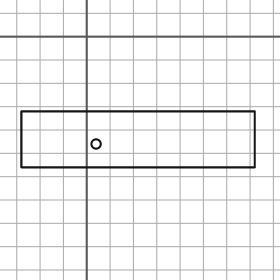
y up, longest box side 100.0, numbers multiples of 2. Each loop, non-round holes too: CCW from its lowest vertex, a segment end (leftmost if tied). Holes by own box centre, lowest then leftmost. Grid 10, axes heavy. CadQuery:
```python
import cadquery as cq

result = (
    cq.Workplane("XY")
    .moveTo(-28.0, -56.0)
    .lineTo(72.0, -56.0)
    .lineTo(72.0, -32.0)
    .lineTo(-28.0, -32.0)
    .close()
    .moveTo(4.0, -46.0)
    .circle(2.0)
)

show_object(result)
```